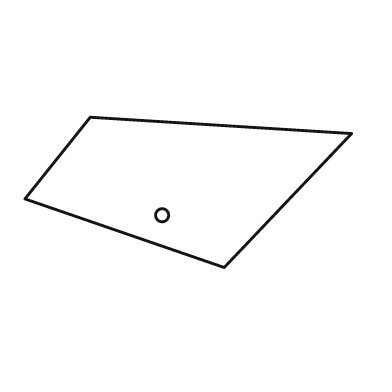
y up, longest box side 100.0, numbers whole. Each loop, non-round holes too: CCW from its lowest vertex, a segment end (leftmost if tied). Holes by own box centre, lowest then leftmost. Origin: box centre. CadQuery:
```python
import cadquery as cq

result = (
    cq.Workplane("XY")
    .moveTo(11.0, -23.0)
    .lineTo(50.0, 18.0)
    .lineTo(-30.0, 23.0)
    .lineTo(-50.0, -2.0)
    .close()
    .moveTo(-8.0, -7.0)
    .circle(2.0)
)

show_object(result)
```